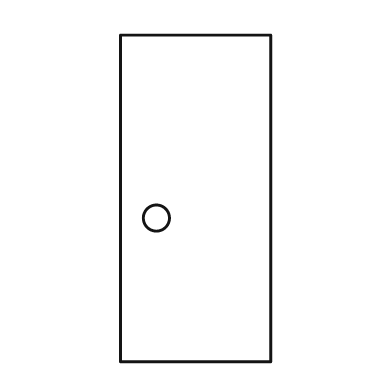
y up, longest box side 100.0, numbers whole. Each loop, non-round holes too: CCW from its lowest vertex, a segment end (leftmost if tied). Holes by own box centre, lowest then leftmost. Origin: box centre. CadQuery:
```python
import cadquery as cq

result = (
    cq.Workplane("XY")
    .moveTo(-23.0, -50.0)
    .lineTo(23.0, -50.0)
    .lineTo(23.0, 50.0)
    .lineTo(-23.0, 50.0)
    .close()
    .moveTo(-12.0, -6.0)
    .circle(4.0)
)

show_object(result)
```